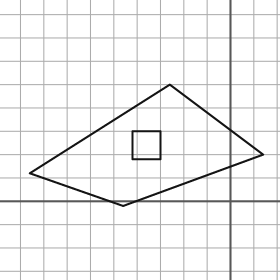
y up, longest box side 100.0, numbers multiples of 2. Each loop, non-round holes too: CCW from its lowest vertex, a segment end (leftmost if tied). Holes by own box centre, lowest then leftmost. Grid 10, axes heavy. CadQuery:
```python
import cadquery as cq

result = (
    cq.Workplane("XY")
    .moveTo(-46.0, -2.0)
    .lineTo(14.0, 20.0)
    .lineTo(-26.0, 50.0)
    .lineTo(-86.0, 12.0)
    .close()
    .moveTo(-42.0, 18.0)
    .lineTo(-30.0, 18.0)
    .lineTo(-30.0, 30.0)
    .lineTo(-42.0, 30.0)
    .close()
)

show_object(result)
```